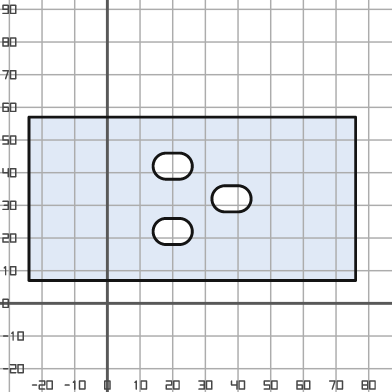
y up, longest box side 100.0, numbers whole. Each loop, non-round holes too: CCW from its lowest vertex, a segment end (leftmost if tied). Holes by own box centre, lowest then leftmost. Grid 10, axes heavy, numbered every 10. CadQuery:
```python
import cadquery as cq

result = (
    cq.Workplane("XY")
    .moveTo(-24.0, 7.0)
    .lineTo(76.0, 7.0)
    .lineTo(76.0, 57.0)
    .lineTo(-24.0, 57.0)
    .close()
    .moveTo(18.0, 18.0)
    .lineTo(22.0, 18.0)
    .threePointArc((26.0, 22.0), (22.0, 26.0))
    .lineTo(18.0, 26.0)
    .threePointArc((14.0, 22.0), (18.0, 18.0))
    .close()
    .moveTo(36.0, 28.0)
    .lineTo(40.0, 28.0)
    .threePointArc((44.0, 32.0), (40.0, 36.0))
    .lineTo(36.0, 36.0)
    .threePointArc((32.0, 32.0), (36.0, 28.0))
    .close()
    .moveTo(18.0, 38.0)
    .lineTo(22.0, 38.0)
    .threePointArc((26.0, 42.0), (22.0, 46.0))
    .lineTo(18.0, 46.0)
    .threePointArc((14.0, 42.0), (18.0, 38.0))
    .close()
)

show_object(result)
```